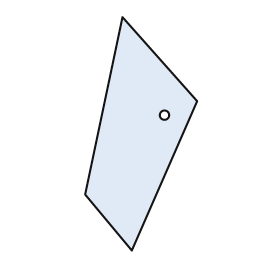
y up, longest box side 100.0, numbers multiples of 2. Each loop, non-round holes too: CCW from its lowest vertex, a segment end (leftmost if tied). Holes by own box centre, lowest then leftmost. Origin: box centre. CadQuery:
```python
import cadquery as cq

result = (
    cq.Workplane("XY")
    .moveTo(-4.0, -50.0)
    .lineTo(24.0, 14.0)
    .lineTo(-8.0, 50.0)
    .lineTo(-24.0, -26.0)
    .close()
    .moveTo(10.0, 8.0)
    .circle(2.0)
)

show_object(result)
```